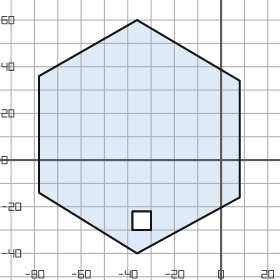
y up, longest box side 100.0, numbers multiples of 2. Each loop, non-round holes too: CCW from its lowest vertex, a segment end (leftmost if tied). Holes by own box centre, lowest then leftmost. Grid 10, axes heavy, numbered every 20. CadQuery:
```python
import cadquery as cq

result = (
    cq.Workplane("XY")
    .moveTo(-36.0, -40.0)
    .lineTo(8.0, -16.0)
    .lineTo(8.0, 34.0)
    .lineTo(-36.0, 60.0)
    .lineTo(-78.0, 36.0)
    .lineTo(-78.0, -14.0)
    .close()
    .moveTo(-38.0, -30.0)
    .lineTo(-30.0, -30.0)
    .lineTo(-30.0, -22.0)
    .lineTo(-38.0, -22.0)
    .close()
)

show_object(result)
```